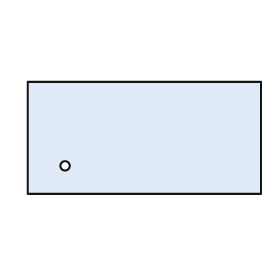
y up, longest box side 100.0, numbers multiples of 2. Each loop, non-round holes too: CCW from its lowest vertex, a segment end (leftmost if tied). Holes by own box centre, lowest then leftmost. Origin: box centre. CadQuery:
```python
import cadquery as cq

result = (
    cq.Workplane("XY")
    .moveTo(-50.0, -24.0)
    .lineTo(50.0, -24.0)
    .lineTo(50.0, 24.0)
    .lineTo(-50.0, 24.0)
    .close()
    .moveTo(-34.0, -12.0)
    .circle(2.0)
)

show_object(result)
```